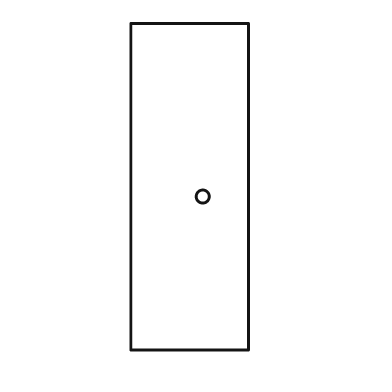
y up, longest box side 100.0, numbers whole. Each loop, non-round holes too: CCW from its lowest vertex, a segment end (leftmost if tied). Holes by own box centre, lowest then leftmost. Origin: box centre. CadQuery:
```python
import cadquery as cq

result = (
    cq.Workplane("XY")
    .moveTo(-18.0, -50.0)
    .lineTo(18.0, -50.0)
    .lineTo(18.0, 50.0)
    .lineTo(-18.0, 50.0)
    .close()
    .moveTo(4.0, -3.0)
    .circle(2.0)
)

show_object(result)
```